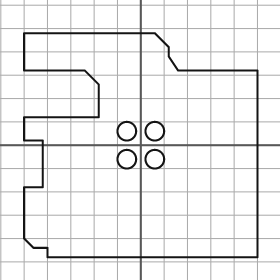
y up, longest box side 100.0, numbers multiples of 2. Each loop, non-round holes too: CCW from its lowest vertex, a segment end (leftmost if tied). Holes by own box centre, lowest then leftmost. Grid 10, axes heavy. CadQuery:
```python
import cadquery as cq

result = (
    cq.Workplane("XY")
    .moveTo(-40.0, -48.0)
    .lineTo(50.0, -48.0)
    .lineTo(50.0, 32.0)
    .lineTo(16.0, 32.0)
    .lineTo(12.0, 38.0)
    .lineTo(12.0, 42.0)
    .lineTo(6.0, 48.0)
    .lineTo(-50.0, 48.0)
    .lineTo(-50.0, 32.0)
    .lineTo(-24.0, 32.0)
    .lineTo(-18.0, 26.0)
    .lineTo(-18.0, 12.0)
    .lineTo(-50.0, 12.0)
    .lineTo(-50.0, 2.0)
    .lineTo(-42.0, 2.0)
    .lineTo(-42.0, -18.0)
    .lineTo(-50.0, -18.0)
    .lineTo(-50.0, -40.0)
    .lineTo(-46.0, -44.0)
    .lineTo(-40.0, -44.0)
    .close()
    .moveTo(-6.0, -6.0)
    .circle(4.0)
    .moveTo(6.0, -6.0)
    .circle(4.0)
    .moveTo(-6.0, 6.0)
    .circle(4.0)
    .moveTo(6.0, 6.0)
    .circle(4.0)
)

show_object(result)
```